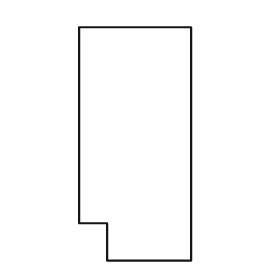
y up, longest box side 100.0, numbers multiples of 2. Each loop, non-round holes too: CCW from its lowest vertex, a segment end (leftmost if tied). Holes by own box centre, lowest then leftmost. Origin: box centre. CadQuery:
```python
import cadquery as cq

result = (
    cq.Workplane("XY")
    .moveTo(-12.0, -50.0)
    .lineTo(24.0, -50.0)
    .lineTo(24.0, 50.0)
    .lineTo(-24.0, 50.0)
    .lineTo(-24.0, -34.0)
    .lineTo(-12.0, -34.0)
    .close()
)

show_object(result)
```